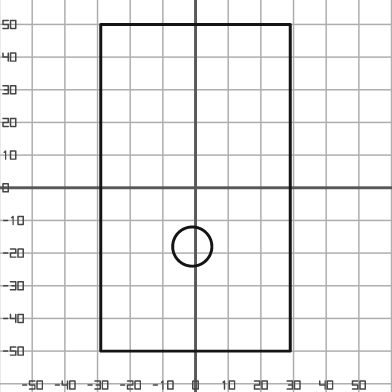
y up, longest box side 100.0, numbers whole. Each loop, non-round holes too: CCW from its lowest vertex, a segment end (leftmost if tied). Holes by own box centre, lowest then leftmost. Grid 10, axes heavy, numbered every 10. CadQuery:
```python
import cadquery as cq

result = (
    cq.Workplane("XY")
    .moveTo(-29.0, -50.0)
    .lineTo(29.0, -50.0)
    .lineTo(29.0, 50.0)
    .lineTo(-29.0, 50.0)
    .close()
    .moveTo(-1.0, -18.0)
    .circle(6.0)
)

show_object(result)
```